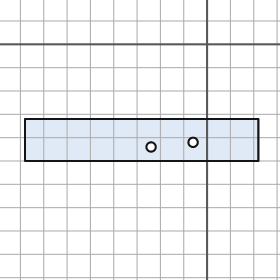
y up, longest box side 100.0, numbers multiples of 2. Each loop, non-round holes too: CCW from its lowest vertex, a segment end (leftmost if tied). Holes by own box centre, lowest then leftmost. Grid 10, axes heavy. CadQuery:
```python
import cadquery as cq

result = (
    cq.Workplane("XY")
    .moveTo(-78.0, -50.0)
    .lineTo(22.0, -50.0)
    .lineTo(22.0, -32.0)
    .lineTo(-78.0, -32.0)
    .close()
    .moveTo(-24.0, -44.0)
    .circle(2.0)
    .moveTo(-6.0, -42.0)
    .circle(2.0)
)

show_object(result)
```